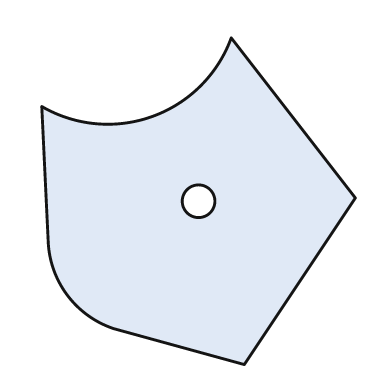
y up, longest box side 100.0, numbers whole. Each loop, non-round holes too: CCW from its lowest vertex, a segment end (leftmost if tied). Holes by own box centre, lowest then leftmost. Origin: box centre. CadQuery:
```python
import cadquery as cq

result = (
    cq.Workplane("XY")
    .moveTo(14.0, -50.0)
    .lineTo(48.0, 1.0)
    .lineTo(10.0, 50.0)
    .threePointArc((-14.0, 26.0), (-48.0, 29.0))
    .lineTo(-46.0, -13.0)
    .threePointArc((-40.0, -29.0), (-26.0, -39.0))
    .close()
    .moveTo(0.0, 0.0)
    .circle(5.0)
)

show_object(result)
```